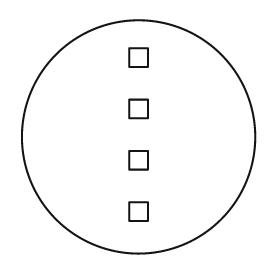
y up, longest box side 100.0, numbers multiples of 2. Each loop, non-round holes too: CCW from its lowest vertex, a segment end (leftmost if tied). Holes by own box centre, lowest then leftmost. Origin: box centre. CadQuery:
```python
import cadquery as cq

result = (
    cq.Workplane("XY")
    .moveTo(0.0, 0.0)
    .circle(50.0)
    .moveTo(-4.0, -36.0)
    .lineTo(4.0, -36.0)
    .lineTo(4.0, -28.0)
    .lineTo(-4.0, -28.0)
    .close()
    .moveTo(-4.0, -14.0)
    .lineTo(4.0, -14.0)
    .lineTo(4.0, -6.0)
    .lineTo(-4.0, -6.0)
    .close()
    .moveTo(-4.0, 8.0)
    .lineTo(4.0, 8.0)
    .lineTo(4.0, 16.0)
    .lineTo(-4.0, 16.0)
    .close()
    .moveTo(-4.0, 30.0)
    .lineTo(4.0, 30.0)
    .lineTo(4.0, 38.0)
    .lineTo(-4.0, 38.0)
    .close()
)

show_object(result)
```